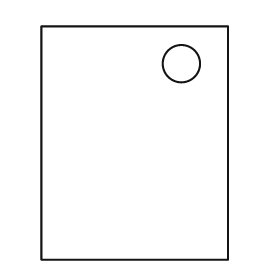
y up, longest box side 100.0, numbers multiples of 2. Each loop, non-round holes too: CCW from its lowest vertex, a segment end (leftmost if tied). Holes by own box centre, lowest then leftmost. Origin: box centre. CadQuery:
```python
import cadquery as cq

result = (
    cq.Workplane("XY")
    .moveTo(-40.0, -50.0)
    .lineTo(40.0, -50.0)
    .lineTo(40.0, 50.0)
    .lineTo(-40.0, 50.0)
    .close()
    .moveTo(20.0, 34.0)
    .circle(8.0)
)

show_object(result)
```